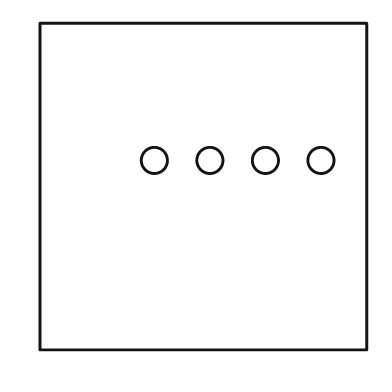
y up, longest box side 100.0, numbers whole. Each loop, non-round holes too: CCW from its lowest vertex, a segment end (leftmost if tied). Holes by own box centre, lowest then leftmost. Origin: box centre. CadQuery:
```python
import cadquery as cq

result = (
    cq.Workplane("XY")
    .moveTo(-50.0, -50.0)
    .lineTo(50.0, -50.0)
    .lineTo(50.0, 50.0)
    .lineTo(-50.0, 50.0)
    .close()
    .moveTo(-15.0, 8.0)
    .circle(4.0)
    .moveTo(2.0, 8.0)
    .circle(4.0)
    .moveTo(19.0, 8.0)
    .circle(4.0)
    .moveTo(36.0, 8.0)
    .circle(4.0)
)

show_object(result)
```